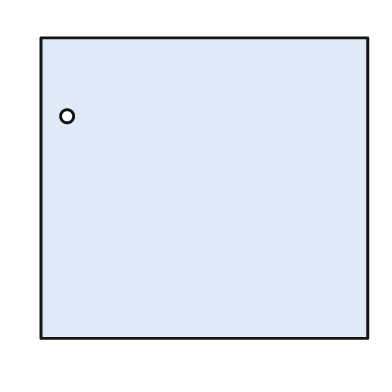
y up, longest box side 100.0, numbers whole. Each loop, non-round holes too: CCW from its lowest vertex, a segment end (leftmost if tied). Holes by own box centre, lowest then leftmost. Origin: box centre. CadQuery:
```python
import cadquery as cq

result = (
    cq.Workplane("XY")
    .moveTo(-50.0, -46.0)
    .lineTo(50.0, -46.0)
    .lineTo(50.0, 46.0)
    .lineTo(-50.0, 46.0)
    .close()
    .moveTo(-42.0, 22.0)
    .circle(2.0)
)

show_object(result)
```